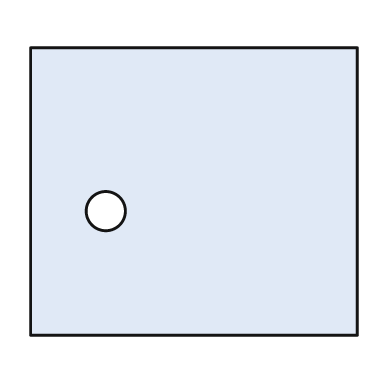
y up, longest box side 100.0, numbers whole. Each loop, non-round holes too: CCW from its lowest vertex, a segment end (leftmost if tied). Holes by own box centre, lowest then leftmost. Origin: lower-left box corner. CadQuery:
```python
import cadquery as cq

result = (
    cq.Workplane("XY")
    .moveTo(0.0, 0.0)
    .lineTo(100.0, 0.0)
    .lineTo(100.0, 88.0)
    .lineTo(0.0, 88.0)
    .close()
    .moveTo(23.0, 38.0)
    .circle(6.0)
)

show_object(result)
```